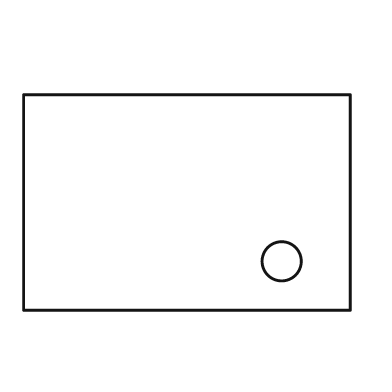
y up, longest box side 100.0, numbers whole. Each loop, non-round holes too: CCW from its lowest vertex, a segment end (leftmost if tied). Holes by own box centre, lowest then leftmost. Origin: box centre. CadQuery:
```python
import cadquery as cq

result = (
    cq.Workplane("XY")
    .moveTo(-50.0, -33.0)
    .lineTo(50.0, -33.0)
    .lineTo(50.0, 33.0)
    .lineTo(-50.0, 33.0)
    .close()
    .moveTo(29.0, -18.0)
    .circle(6.0)
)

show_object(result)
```